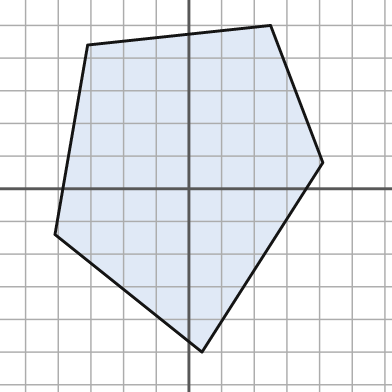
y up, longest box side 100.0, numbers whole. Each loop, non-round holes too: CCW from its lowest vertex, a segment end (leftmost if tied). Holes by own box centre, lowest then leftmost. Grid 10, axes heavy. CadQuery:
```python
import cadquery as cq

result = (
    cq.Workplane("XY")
    .moveTo(4.0, -50.0)
    .lineTo(41.0, 8.0)
    .lineTo(25.0, 50.0)
    .lineTo(-31.0, 44.0)
    .lineTo(-41.0, -14.0)
    .close()
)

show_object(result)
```